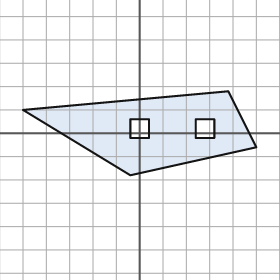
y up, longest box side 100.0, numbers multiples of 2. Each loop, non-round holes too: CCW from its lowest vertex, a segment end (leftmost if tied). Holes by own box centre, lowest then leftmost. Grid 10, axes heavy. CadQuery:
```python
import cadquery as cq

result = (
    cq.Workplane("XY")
    .moveTo(-4.0, -18.0)
    .lineTo(50.0, -6.0)
    .lineTo(38.0, 18.0)
    .lineTo(-50.0, 10.0)
    .close()
    .moveTo(-4.0, -2.0)
    .lineTo(4.0, -2.0)
    .lineTo(4.0, 6.0)
    .lineTo(-4.0, 6.0)
    .close()
    .moveTo(24.0, -2.0)
    .lineTo(32.0, -2.0)
    .lineTo(32.0, 6.0)
    .lineTo(24.0, 6.0)
    .close()
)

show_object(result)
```